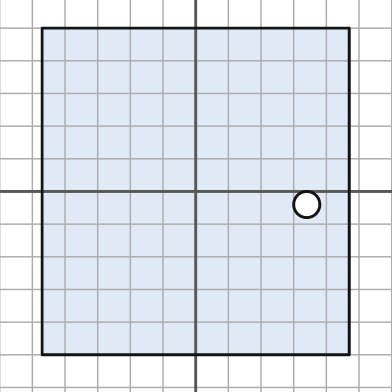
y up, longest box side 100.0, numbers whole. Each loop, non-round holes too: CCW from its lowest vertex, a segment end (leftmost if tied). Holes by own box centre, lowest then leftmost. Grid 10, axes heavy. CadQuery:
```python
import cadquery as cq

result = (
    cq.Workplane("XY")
    .moveTo(-47.0, -50.0)
    .lineTo(47.0, -50.0)
    .lineTo(47.0, 50.0)
    .lineTo(-47.0, 50.0)
    .close()
    .moveTo(34.0, -4.0)
    .circle(4.0)
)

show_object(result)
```